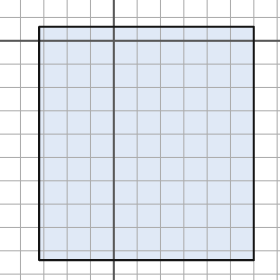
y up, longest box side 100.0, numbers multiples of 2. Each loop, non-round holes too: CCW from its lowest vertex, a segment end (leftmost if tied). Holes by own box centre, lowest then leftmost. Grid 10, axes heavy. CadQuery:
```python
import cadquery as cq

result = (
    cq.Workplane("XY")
    .moveTo(-32.0, -94.0)
    .lineTo(60.0, -94.0)
    .lineTo(60.0, 6.0)
    .lineTo(-32.0, 6.0)
    .close()
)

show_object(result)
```